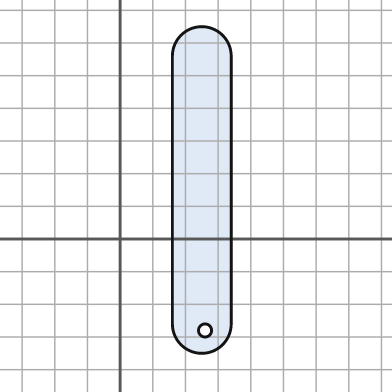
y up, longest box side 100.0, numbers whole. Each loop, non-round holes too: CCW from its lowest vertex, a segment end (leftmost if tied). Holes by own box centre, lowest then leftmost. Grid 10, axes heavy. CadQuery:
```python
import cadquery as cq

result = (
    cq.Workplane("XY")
    .moveTo(16.0, -26.0)
    .threePointArc((25.0, -35.0), (34.0, -26.0))
    .lineTo(34.0, 56.0)
    .threePointArc((25.0, 65.0), (16.0, 56.0))
    .close()
    .moveTo(26.0, -28.0)
    .circle(2.0)
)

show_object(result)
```